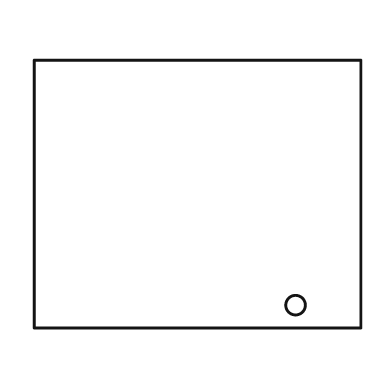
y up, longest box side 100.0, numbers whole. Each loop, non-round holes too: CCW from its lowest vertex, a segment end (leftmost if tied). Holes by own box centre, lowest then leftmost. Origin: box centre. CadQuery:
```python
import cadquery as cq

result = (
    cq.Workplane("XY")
    .moveTo(-50.0, -41.0)
    .lineTo(50.0, -41.0)
    .lineTo(50.0, 41.0)
    .lineTo(-50.0, 41.0)
    .close()
    .moveTo(30.0, -34.0)
    .circle(3.0)
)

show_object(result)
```